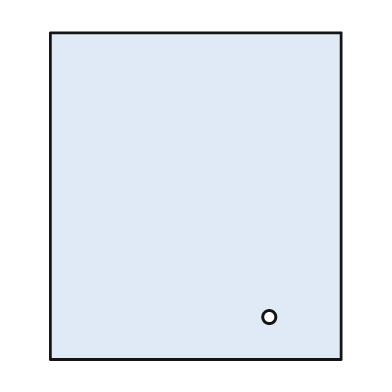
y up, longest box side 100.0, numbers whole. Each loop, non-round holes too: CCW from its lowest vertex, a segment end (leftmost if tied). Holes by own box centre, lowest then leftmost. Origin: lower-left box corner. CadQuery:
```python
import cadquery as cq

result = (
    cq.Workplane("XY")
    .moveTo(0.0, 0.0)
    .lineTo(89.0, 0.0)
    .lineTo(89.0, 100.0)
    .lineTo(0.0, 100.0)
    .close()
    .moveTo(67.0, 13.0)
    .circle(2.0)
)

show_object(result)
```